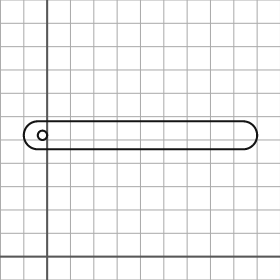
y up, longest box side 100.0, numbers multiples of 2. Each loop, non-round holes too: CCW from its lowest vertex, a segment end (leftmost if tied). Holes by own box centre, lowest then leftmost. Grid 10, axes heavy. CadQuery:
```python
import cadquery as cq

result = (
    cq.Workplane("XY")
    .moveTo(-4.0, 46.0)
    .lineTo(84.0, 46.0)
    .threePointArc((90.0, 52.0), (84.0, 58.0))
    .lineTo(-4.0, 58.0)
    .threePointArc((-10.0, 52.0), (-4.0, 46.0))
    .close()
    .moveTo(-2.0, 52.0)
    .circle(2.0)
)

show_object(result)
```